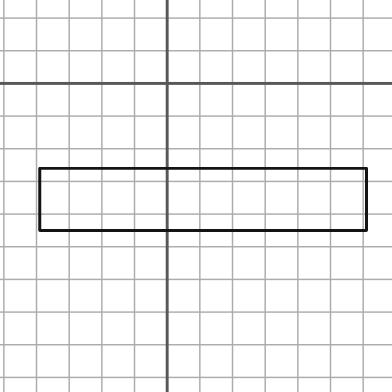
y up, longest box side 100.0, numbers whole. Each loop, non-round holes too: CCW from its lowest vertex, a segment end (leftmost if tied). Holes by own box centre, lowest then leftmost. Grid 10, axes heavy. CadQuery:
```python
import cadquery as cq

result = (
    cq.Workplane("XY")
    .moveTo(-39.0, -45.0)
    .lineTo(61.0, -45.0)
    .lineTo(61.0, -26.0)
    .lineTo(-39.0, -26.0)
    .close()
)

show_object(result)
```